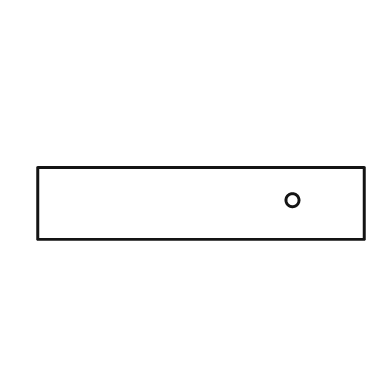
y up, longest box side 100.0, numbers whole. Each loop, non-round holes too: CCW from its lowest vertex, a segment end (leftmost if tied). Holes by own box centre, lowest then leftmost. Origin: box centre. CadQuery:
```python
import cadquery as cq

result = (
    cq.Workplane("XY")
    .moveTo(-50.0, -11.0)
    .lineTo(50.0, -11.0)
    .lineTo(50.0, 11.0)
    .lineTo(-50.0, 11.0)
    .close()
    .moveTo(28.0, 1.0)
    .circle(2.0)
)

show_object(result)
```